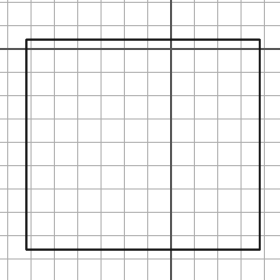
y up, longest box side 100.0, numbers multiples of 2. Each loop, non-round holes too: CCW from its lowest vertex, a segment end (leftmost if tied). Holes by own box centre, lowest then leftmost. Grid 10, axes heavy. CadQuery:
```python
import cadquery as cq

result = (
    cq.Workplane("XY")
    .moveTo(-62.0, -86.0)
    .lineTo(38.0, -86.0)
    .lineTo(38.0, 4.0)
    .lineTo(-62.0, 4.0)
    .close()
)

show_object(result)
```